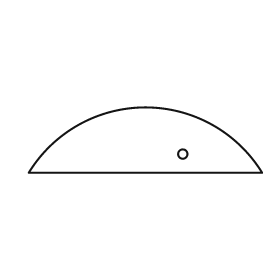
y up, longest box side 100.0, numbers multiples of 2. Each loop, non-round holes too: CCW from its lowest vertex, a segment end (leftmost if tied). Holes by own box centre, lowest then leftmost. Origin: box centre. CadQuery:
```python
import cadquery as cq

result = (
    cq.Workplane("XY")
    .moveTo(-50.0, -14.0)
    .lineTo(50.0, -14.0)
    .threePointArc((0.0, 14.0), (-50.0, -14.0))
    .close()
    .moveTo(16.0, -6.0)
    .circle(2.0)
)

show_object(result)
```